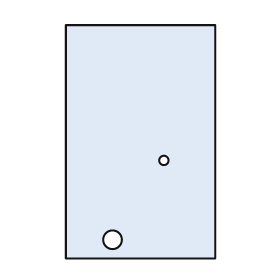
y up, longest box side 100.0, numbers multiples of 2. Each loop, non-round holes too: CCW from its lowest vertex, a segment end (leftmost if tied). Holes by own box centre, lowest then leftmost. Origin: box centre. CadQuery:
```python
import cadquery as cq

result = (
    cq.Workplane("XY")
    .moveTo(-32.0, -50.0)
    .lineTo(32.0, -50.0)
    .lineTo(32.0, 50.0)
    .lineTo(-32.0, 50.0)
    .close()
    .moveTo(-12.0, -42.0)
    .circle(4.0)
    .moveTo(10.0, -8.0)
    .circle(2.0)
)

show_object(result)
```